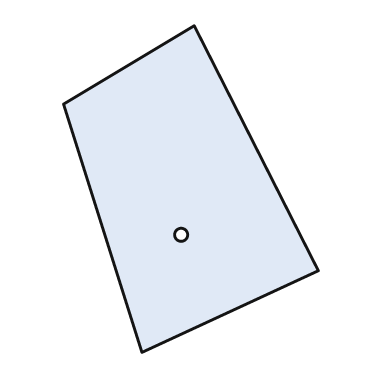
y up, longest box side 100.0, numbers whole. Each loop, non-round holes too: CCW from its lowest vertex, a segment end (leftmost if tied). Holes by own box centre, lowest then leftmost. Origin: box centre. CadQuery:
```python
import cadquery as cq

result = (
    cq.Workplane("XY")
    .moveTo(-15.0, -50.0)
    .lineTo(39.0, -25.0)
    .lineTo(1.0, 50.0)
    .lineTo(-39.0, 26.0)
    .close()
    .moveTo(-3.0, -14.0)
    .circle(2.0)
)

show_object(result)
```